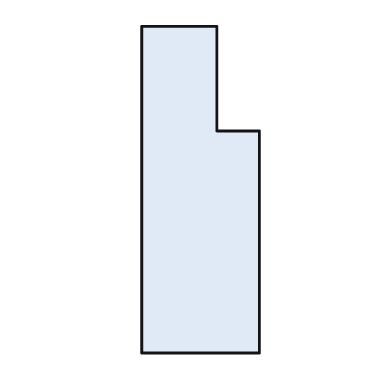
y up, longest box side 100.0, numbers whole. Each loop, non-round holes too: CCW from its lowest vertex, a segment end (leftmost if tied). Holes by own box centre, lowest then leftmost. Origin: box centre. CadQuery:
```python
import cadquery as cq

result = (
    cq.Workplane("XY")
    .moveTo(-18.0, -50.0)
    .lineTo(18.0, -50.0)
    .lineTo(18.0, 18.0)
    .lineTo(5.0, 18.0)
    .lineTo(5.0, 50.0)
    .lineTo(-18.0, 50.0)
    .close()
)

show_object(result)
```